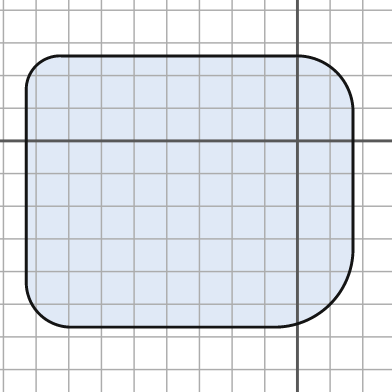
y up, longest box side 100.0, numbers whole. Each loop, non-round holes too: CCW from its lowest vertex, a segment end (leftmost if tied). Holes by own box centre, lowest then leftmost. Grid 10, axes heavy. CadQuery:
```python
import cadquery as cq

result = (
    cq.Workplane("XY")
    .moveTo(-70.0, -57.0)
    .lineTo(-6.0, -57.0)
    .threePointArc((10.0, -50.0), (17.0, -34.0))
    .lineTo(17.0, 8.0)
    .threePointArc((12.0, 21.0), (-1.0, 26.0))
    .lineTo(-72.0, 26.0)
    .threePointArc((-80.0, 23.0), (-83.0, 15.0))
    .lineTo(-83.0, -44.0)
    .threePointArc((-79.0, -53.0), (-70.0, -57.0))
    .close()
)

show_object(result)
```